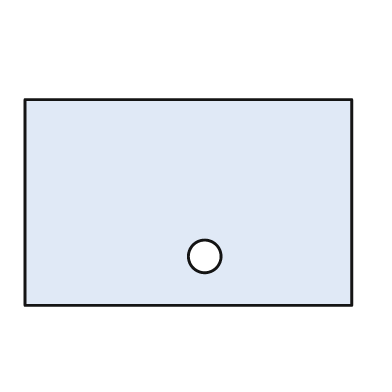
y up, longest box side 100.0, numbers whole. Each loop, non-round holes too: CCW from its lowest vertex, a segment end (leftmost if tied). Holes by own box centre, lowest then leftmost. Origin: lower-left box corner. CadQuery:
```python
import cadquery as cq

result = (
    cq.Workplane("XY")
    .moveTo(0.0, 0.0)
    .lineTo(100.0, 0.0)
    .lineTo(100.0, 63.0)
    .lineTo(0.0, 63.0)
    .close()
    .moveTo(55.0, 15.0)
    .circle(5.0)
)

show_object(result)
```